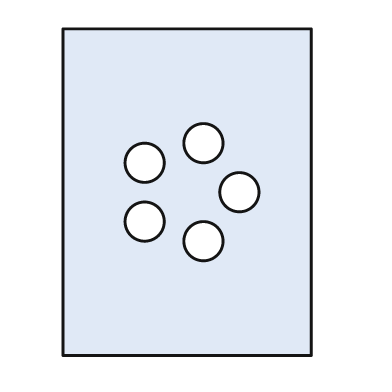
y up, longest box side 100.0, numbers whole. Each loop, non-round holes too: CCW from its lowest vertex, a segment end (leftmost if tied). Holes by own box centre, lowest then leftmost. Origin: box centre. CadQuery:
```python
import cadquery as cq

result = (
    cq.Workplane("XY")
    .moveTo(-38.0, -50.0)
    .lineTo(38.0, -50.0)
    .lineTo(38.0, 50.0)
    .lineTo(-38.0, 50.0)
    .close()
    .moveTo(5.0, -15.0)
    .circle(6.0)
    .moveTo(-13.0, -9.0)
    .circle(6.0)
    .moveTo(16.0, 0.0)
    .circle(6.0)
    .moveTo(-13.0, 9.0)
    .circle(6.0)
    .moveTo(5.0, 15.0)
    .circle(6.0)
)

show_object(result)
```